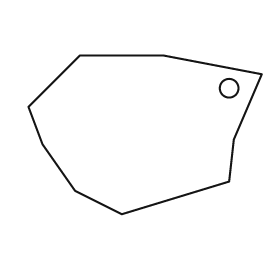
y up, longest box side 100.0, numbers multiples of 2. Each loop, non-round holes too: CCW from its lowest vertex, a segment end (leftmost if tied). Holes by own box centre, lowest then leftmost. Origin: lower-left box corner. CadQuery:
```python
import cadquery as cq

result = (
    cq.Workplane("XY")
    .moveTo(40.0, 0.0)
    .lineTo(86.0, 14.0)
    .lineTo(88.0, 32.0)
    .lineTo(100.0, 60.0)
    .lineTo(58.0, 68.0)
    .lineTo(22.0, 68.0)
    .lineTo(0.0, 46.0)
    .lineTo(6.0, 30.0)
    .lineTo(20.0, 10.0)
    .close()
    .moveTo(86.0, 54.0)
    .circle(4.0)
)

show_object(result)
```